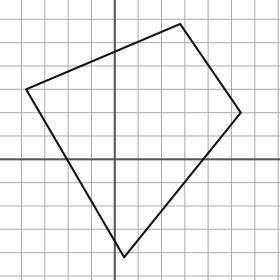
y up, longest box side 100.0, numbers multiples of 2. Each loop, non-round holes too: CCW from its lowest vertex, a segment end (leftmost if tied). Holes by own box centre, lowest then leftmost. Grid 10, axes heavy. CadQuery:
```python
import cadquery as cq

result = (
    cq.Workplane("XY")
    .moveTo(4.0, -42.0)
    .lineTo(54.0, 20.0)
    .lineTo(28.0, 58.0)
    .lineTo(-38.0, 30.0)
    .close()
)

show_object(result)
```